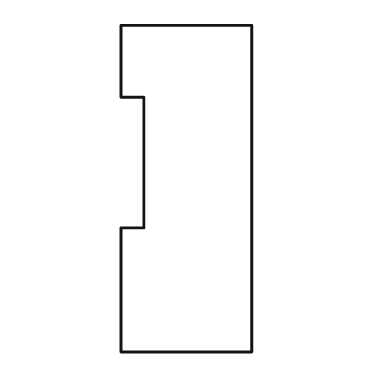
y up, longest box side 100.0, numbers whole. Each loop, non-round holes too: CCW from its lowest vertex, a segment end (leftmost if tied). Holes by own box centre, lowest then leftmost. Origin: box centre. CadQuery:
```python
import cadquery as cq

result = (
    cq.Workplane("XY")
    .moveTo(-20.0, -50.0)
    .lineTo(20.0, -50.0)
    .lineTo(20.0, 50.0)
    .lineTo(-20.0, 50.0)
    .lineTo(-20.0, 28.0)
    .lineTo(-13.0, 28.0)
    .lineTo(-13.0, -12.0)
    .lineTo(-20.0, -12.0)
    .close()
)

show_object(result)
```